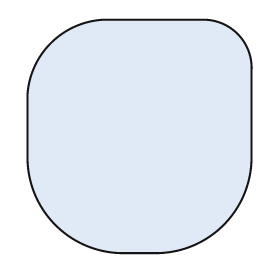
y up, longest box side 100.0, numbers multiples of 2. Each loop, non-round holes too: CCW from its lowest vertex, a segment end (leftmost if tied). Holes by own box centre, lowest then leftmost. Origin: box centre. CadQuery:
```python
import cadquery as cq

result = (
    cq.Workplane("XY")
    .moveTo(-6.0, -50.0)
    .lineTo(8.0, -50.0)
    .threePointArc((36.0, -38.0), (48.0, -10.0))
    .lineTo(48.0, 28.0)
    .threePointArc((42.0, 44.0), (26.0, 50.0))
    .lineTo(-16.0, 50.0)
    .threePointArc((-38.0, 40.0), (-48.0, 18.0))
    .lineTo(-48.0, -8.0)
    .threePointArc((-36.0, -38.0), (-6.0, -50.0))
    .close()
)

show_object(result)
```